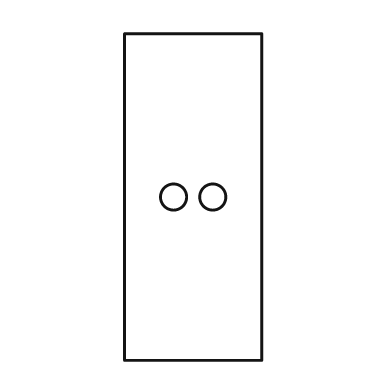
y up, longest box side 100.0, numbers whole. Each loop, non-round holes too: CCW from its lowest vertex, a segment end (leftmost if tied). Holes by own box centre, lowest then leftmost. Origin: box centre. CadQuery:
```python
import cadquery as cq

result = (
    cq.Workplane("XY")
    .moveTo(-21.0, -50.0)
    .lineTo(21.0, -50.0)
    .lineTo(21.0, 50.0)
    .lineTo(-21.0, 50.0)
    .close()
    .moveTo(-6.0, 0.0)
    .circle(4.0)
    .moveTo(6.0, 0.0)
    .circle(4.0)
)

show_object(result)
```